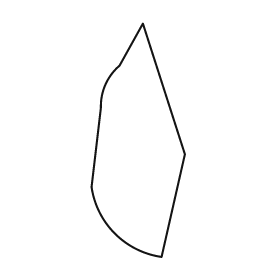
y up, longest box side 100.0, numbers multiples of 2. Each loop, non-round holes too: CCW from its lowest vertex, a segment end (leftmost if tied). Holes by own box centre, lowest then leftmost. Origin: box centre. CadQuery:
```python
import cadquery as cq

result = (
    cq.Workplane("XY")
    .moveTo(10.0, -50.0)
    .lineTo(20.0, -6.0)
    .lineTo(2.0, 50.0)
    .lineTo(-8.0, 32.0)
    .threePointArc((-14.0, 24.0), (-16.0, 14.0))
    .lineTo(-20.0, -20.0)
    .threePointArc((-10.0, -40.0), (10.0, -50.0))
    .close()
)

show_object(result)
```